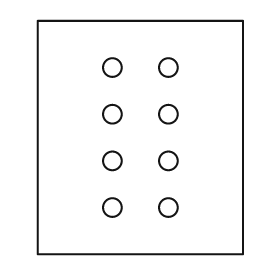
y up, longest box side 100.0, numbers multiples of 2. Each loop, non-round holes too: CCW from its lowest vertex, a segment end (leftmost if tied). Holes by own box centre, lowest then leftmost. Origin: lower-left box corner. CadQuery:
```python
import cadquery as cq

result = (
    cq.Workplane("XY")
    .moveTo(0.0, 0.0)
    .lineTo(88.0, 0.0)
    .lineTo(88.0, 100.0)
    .lineTo(0.0, 100.0)
    .close()
    .moveTo(32.0, 20.0)
    .circle(4.0)
    .moveTo(56.0, 20.0)
    .circle(4.0)
    .moveTo(32.0, 40.0)
    .circle(4.0)
    .moveTo(56.0, 40.0)
    .circle(4.0)
    .moveTo(32.0, 60.0)
    .circle(4.0)
    .moveTo(56.0, 60.0)
    .circle(4.0)
    .moveTo(32.0, 80.0)
    .circle(4.0)
    .moveTo(56.0, 80.0)
    .circle(4.0)
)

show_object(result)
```